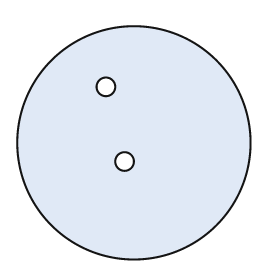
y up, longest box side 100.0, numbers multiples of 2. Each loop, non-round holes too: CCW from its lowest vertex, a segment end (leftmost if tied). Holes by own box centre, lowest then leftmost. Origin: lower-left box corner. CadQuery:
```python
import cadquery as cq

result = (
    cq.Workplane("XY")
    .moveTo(50.0, 50.0)
    .circle(50.0)
    .moveTo(46.0, 42.0)
    .circle(4.0)
    .moveTo(38.0, 74.0)
    .circle(4.0)
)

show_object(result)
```